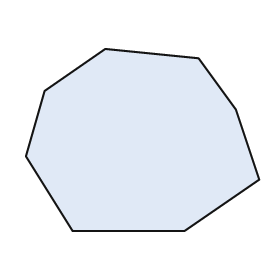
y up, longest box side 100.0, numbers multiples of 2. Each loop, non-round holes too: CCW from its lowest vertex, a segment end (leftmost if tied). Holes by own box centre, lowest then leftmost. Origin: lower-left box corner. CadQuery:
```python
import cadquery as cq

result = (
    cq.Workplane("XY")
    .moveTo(20.0, 0.0)
    .lineTo(68.0, 0.0)
    .lineTo(100.0, 22.0)
    .lineTo(90.0, 52.0)
    .lineTo(74.0, 74.0)
    .lineTo(34.0, 78.0)
    .lineTo(8.0, 60.0)
    .lineTo(0.0, 32.0)
    .close()
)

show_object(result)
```